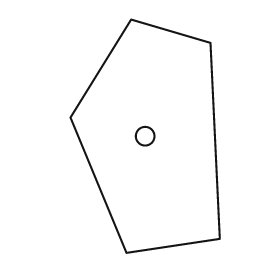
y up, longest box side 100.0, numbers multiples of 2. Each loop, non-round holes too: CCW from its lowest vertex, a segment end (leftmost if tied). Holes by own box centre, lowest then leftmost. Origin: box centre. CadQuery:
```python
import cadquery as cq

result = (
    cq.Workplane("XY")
    .moveTo(-8.0, -50.0)
    .lineTo(32.0, -44.0)
    .lineTo(28.0, 40.0)
    .lineTo(-6.0, 50.0)
    .lineTo(-32.0, 8.0)
    .close()
    .moveTo(0.0, 0.0)
    .circle(4.0)
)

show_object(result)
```